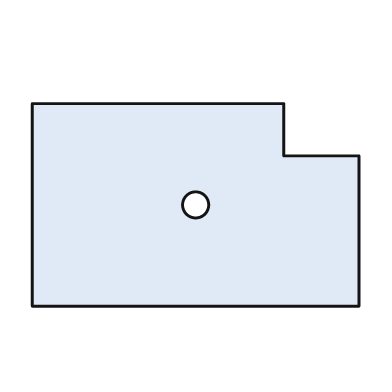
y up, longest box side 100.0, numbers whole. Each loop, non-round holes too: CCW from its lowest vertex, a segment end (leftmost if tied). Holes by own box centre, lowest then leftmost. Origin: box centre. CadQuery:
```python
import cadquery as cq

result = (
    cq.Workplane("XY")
    .moveTo(-50.0, -31.0)
    .lineTo(50.0, -31.0)
    .lineTo(50.0, 15.0)
    .lineTo(27.0, 15.0)
    .lineTo(27.0, 31.0)
    .lineTo(-50.0, 31.0)
    .close()
    .moveTo(0.0, 0.0)
    .circle(4.0)
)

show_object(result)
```